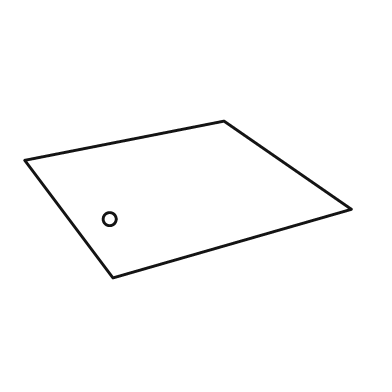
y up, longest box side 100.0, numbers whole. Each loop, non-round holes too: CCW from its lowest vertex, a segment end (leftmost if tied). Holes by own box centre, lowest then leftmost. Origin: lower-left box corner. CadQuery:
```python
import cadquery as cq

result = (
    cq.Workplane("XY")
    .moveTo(27.0, 0.0)
    .lineTo(100.0, 21.0)
    .lineTo(61.0, 48.0)
    .lineTo(0.0, 36.0)
    .close()
    .moveTo(26.0, 18.0)
    .circle(2.0)
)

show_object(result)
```